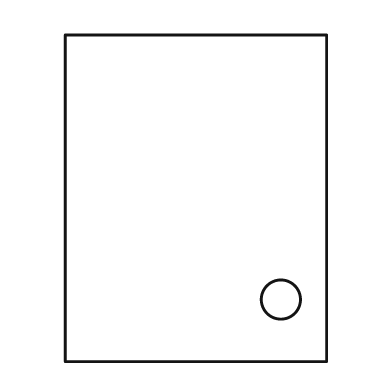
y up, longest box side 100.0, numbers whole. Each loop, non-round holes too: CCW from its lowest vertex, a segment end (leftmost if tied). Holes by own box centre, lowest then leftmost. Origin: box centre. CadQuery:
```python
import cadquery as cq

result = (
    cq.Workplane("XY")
    .moveTo(-40.0, -50.0)
    .lineTo(40.0, -50.0)
    .lineTo(40.0, 50.0)
    .lineTo(-40.0, 50.0)
    .close()
    .moveTo(26.0, -31.0)
    .circle(6.0)
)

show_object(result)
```